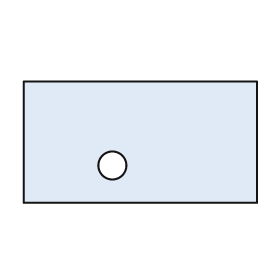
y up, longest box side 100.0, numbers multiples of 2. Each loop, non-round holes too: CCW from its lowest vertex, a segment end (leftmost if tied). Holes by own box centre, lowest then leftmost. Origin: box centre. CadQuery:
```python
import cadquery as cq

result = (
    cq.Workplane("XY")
    .moveTo(-50.0, -26.0)
    .lineTo(50.0, -26.0)
    .lineTo(50.0, 26.0)
    .lineTo(-50.0, 26.0)
    .close()
    .moveTo(-12.0, -10.0)
    .circle(6.0)
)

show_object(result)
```